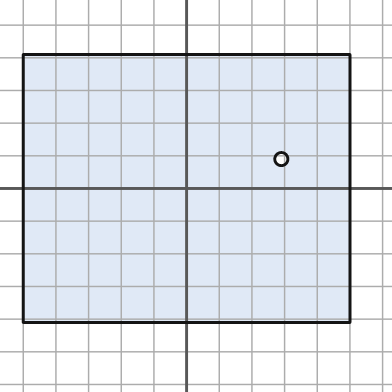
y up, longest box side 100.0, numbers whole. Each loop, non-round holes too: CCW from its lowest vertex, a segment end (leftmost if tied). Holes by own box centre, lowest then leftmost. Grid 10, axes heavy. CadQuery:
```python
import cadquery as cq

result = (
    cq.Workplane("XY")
    .moveTo(-50.0, -41.0)
    .lineTo(50.0, -41.0)
    .lineTo(50.0, 41.0)
    .lineTo(-50.0, 41.0)
    .close()
    .moveTo(29.0, 9.0)
    .circle(2.0)
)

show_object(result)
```